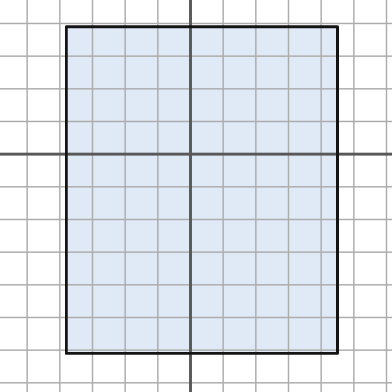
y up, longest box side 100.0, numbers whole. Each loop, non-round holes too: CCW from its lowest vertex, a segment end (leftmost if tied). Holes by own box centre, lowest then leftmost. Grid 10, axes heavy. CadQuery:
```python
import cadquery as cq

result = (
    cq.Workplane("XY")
    .moveTo(-38.0, -61.0)
    .lineTo(45.0, -61.0)
    .lineTo(45.0, 39.0)
    .lineTo(-38.0, 39.0)
    .close()
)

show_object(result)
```